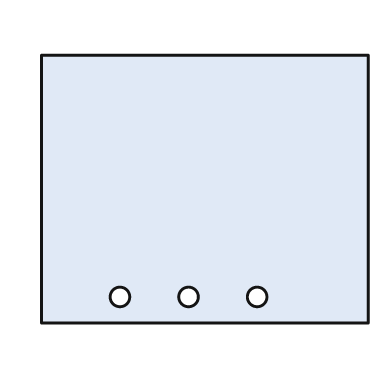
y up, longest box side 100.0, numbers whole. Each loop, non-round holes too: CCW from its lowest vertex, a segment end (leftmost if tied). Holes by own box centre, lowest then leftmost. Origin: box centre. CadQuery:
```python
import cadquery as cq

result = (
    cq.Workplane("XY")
    .moveTo(-50.0, -41.0)
    .lineTo(50.0, -41.0)
    .lineTo(50.0, 41.0)
    .lineTo(-50.0, 41.0)
    .close()
    .moveTo(-26.0, -33.0)
    .circle(3.0)
    .moveTo(-5.0, -33.0)
    .circle(3.0)
    .moveTo(16.0, -33.0)
    .circle(3.0)
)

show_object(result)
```